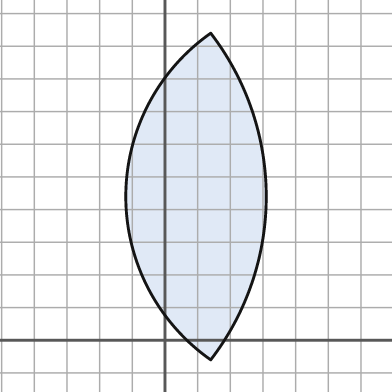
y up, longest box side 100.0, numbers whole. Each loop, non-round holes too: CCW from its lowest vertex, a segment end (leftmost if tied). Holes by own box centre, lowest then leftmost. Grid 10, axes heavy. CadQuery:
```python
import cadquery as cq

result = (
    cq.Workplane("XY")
    .moveTo(14.0, -6.0)
    .threePointArc((31.0, 44.0), (14.0, 94.0))
    .threePointArc((-12.0, 44.0), (14.0, -6.0))
    .close()
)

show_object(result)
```